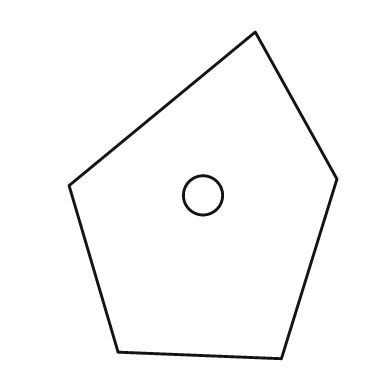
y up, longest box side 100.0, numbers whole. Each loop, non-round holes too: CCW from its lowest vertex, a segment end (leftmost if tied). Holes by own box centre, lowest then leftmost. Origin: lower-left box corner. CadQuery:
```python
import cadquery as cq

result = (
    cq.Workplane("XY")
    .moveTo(65.0, 0.0)
    .lineTo(82.0, 55.0)
    .lineTo(57.0, 100.0)
    .lineTo(0.0, 53.0)
    .lineTo(15.0, 2.0)
    .close()
    .moveTo(41.0, 50.0)
    .circle(6.0)
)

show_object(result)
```